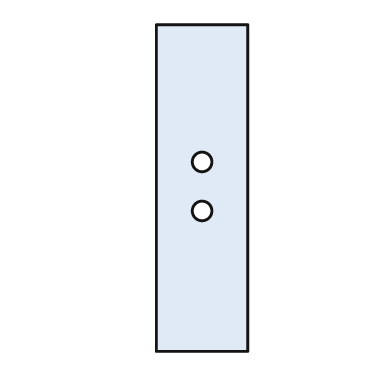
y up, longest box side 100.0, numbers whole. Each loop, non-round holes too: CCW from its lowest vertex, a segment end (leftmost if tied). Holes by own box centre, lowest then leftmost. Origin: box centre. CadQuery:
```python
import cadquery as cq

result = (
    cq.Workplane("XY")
    .moveTo(-14.0, -50.0)
    .lineTo(14.0, -50.0)
    .lineTo(14.0, 50.0)
    .lineTo(-14.0, 50.0)
    .close()
    .moveTo(0.0, -7.0)
    .circle(3.0)
    .moveTo(0.0, 8.0)
    .circle(3.0)
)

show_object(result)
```